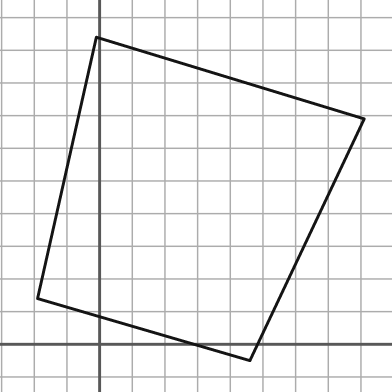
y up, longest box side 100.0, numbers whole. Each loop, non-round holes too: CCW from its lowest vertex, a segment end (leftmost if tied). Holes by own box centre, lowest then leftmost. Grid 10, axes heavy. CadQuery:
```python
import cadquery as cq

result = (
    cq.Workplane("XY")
    .moveTo(46.0, -5.0)
    .lineTo(81.0, 69.0)
    .lineTo(-1.0, 94.0)
    .lineTo(-19.0, 14.0)
    .close()
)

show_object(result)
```